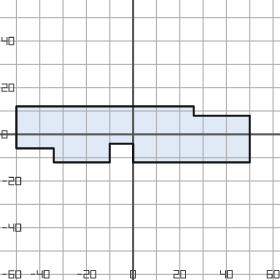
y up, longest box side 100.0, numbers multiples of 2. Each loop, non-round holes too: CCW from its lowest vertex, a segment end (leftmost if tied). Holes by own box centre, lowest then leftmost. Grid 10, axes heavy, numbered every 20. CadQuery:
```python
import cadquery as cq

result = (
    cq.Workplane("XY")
    .moveTo(-34.0, -12.0)
    .lineTo(-10.0, -12.0)
    .lineTo(-10.0, -4.0)
    .lineTo(0.0, -4.0)
    .lineTo(0.0, -12.0)
    .lineTo(50.0, -12.0)
    .lineTo(50.0, 8.0)
    .lineTo(26.0, 8.0)
    .lineTo(26.0, 12.0)
    .lineTo(-50.0, 12.0)
    .lineTo(-50.0, -6.0)
    .lineTo(-34.0, -6.0)
    .close()
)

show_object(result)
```